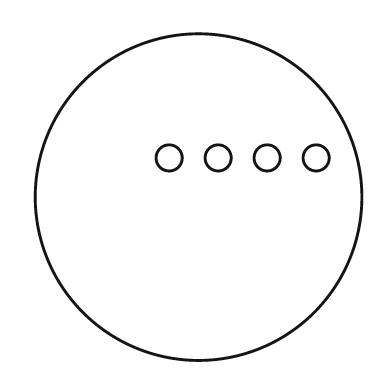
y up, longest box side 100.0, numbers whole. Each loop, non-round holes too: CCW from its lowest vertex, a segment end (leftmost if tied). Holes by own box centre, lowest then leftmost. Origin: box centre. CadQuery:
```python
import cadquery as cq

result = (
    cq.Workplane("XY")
    .moveTo(0.0, 0.0)
    .circle(50.0)
    .moveTo(-9.0, 12.0)
    .circle(4.0)
    .moveTo(6.0, 12.0)
    .circle(4.0)
    .moveTo(21.0, 12.0)
    .circle(4.0)
    .moveTo(36.0, 12.0)
    .circle(4.0)
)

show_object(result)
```